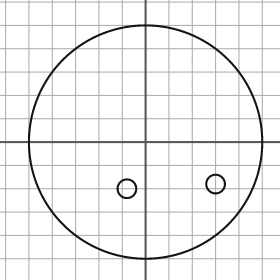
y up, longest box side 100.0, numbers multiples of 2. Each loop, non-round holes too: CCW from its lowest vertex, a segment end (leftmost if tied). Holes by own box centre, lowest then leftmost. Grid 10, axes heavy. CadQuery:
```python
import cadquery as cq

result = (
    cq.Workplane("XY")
    .moveTo(0.0, 0.0)
    .circle(50.0)
    .moveTo(-8.0, -20.0)
    .circle(4.0)
    .moveTo(30.0, -18.0)
    .circle(4.0)
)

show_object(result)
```